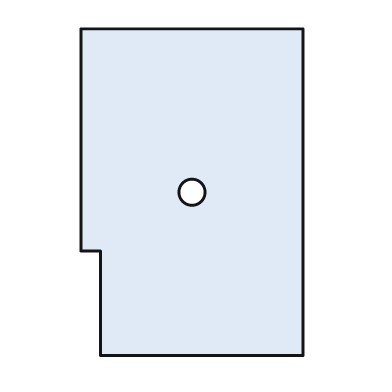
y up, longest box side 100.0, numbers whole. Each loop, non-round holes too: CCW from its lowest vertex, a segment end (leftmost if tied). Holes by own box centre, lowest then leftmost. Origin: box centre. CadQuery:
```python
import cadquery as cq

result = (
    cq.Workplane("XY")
    .moveTo(-28.0, -50.0)
    .lineTo(34.0, -50.0)
    .lineTo(34.0, 50.0)
    .lineTo(-34.0, 50.0)
    .lineTo(-34.0, -18.0)
    .lineTo(-28.0, -18.0)
    .close()
    .moveTo(0.0, 0.0)
    .circle(4.0)
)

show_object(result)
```